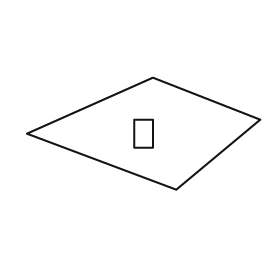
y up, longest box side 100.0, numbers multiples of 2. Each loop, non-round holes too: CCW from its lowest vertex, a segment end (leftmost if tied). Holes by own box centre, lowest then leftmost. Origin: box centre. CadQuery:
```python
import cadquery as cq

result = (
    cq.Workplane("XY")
    .moveTo(14.0, -24.0)
    .lineTo(50.0, 6.0)
    .lineTo(4.0, 24.0)
    .lineTo(-50.0, 0.0)
    .close()
    .moveTo(-4.0, -6.0)
    .lineTo(4.0, -6.0)
    .lineTo(4.0, 6.0)
    .lineTo(-4.0, 6.0)
    .close()
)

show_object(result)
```